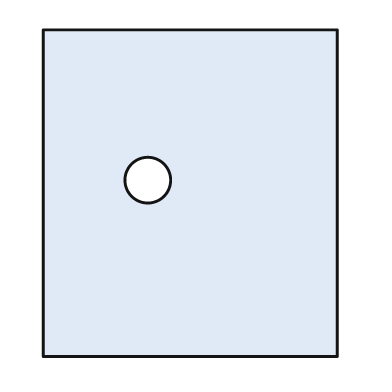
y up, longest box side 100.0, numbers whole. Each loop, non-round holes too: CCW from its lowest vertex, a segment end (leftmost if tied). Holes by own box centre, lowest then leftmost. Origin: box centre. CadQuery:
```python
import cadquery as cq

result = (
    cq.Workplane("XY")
    .moveTo(-45.0, -50.0)
    .lineTo(45.0, -50.0)
    .lineTo(45.0, 50.0)
    .lineTo(-45.0, 50.0)
    .close()
    .moveTo(-13.0, 4.0)
    .circle(7.0)
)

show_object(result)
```